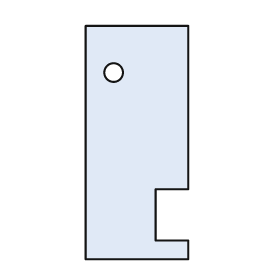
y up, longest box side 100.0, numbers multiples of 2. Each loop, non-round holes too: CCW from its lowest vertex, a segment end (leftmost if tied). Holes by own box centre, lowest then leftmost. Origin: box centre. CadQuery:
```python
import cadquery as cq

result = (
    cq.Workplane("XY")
    .moveTo(-22.0, -50.0)
    .lineTo(22.0, -50.0)
    .lineTo(22.0, -42.0)
    .lineTo(8.0, -42.0)
    .lineTo(8.0, -20.0)
    .lineTo(22.0, -20.0)
    .lineTo(22.0, 50.0)
    .lineTo(-22.0, 50.0)
    .close()
    .moveTo(-10.0, 30.0)
    .circle(4.0)
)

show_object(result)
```